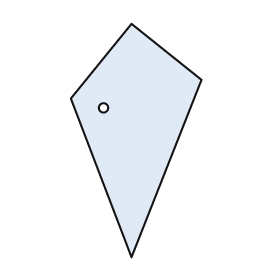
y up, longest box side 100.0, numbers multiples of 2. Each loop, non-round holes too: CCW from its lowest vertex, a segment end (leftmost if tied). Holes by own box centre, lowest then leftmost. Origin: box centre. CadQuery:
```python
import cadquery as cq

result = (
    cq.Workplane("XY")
    .moveTo(-2.0, -50.0)
    .lineTo(28.0, 26.0)
    .lineTo(-2.0, 50.0)
    .lineTo(-28.0, 18.0)
    .close()
    .moveTo(-14.0, 14.0)
    .circle(2.0)
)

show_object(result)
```